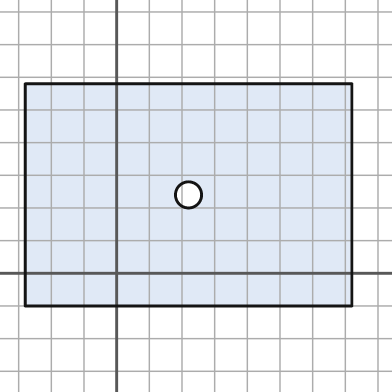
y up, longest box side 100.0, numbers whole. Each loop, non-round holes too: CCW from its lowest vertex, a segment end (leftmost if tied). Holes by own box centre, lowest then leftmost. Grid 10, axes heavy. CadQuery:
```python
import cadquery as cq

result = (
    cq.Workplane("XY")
    .moveTo(-28.0, -10.0)
    .lineTo(72.0, -10.0)
    .lineTo(72.0, 58.0)
    .lineTo(-28.0, 58.0)
    .close()
    .moveTo(22.0, 24.0)
    .circle(4.0)
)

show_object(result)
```